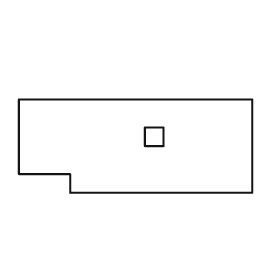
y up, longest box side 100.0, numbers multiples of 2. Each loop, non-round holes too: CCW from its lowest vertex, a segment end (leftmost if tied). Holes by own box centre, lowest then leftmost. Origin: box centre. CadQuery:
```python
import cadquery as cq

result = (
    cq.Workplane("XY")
    .moveTo(-28.0, -20.0)
    .lineTo(50.0, -20.0)
    .lineTo(50.0, 20.0)
    .lineTo(-50.0, 20.0)
    .lineTo(-50.0, -12.0)
    .lineTo(-28.0, -12.0)
    .close()
    .moveTo(4.0, 0.0)
    .lineTo(12.0, 0.0)
    .lineTo(12.0, 8.0)
    .lineTo(4.0, 8.0)
    .close()
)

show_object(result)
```